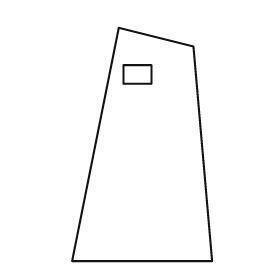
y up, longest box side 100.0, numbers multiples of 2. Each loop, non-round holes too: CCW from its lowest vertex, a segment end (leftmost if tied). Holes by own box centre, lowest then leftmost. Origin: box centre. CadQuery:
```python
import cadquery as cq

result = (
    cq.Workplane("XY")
    .moveTo(-30.0, -50.0)
    .lineTo(30.0, -50.0)
    .lineTo(22.0, 42.0)
    .lineTo(-10.0, 50.0)
    .close()
    .moveTo(-8.0, 26.0)
    .lineTo(4.0, 26.0)
    .lineTo(4.0, 34.0)
    .lineTo(-8.0, 34.0)
    .close()
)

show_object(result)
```